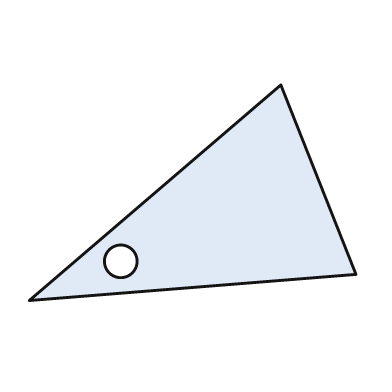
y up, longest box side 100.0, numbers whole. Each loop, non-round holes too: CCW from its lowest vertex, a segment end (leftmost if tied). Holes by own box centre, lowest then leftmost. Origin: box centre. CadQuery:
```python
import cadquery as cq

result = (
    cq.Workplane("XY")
    .moveTo(-50.0, -33.0)
    .lineTo(50.0, -25.0)
    .lineTo(27.0, 33.0)
    .close()
    .moveTo(-22.0, -21.0)
    .circle(5.0)
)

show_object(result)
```